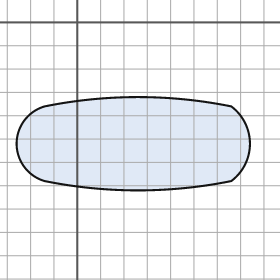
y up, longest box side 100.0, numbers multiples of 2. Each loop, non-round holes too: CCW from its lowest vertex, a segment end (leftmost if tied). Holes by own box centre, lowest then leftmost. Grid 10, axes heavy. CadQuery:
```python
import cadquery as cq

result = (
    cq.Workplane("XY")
    .moveTo(-14.0, -68.0)
    .threePointArc((26.0, -72.0), (66.0, -68.0))
    .threePointArc((74.0, -52.0), (66.0, -36.0))
    .threePointArc((26.0, -32.0), (-14.0, -36.0))
    .threePointArc((-26.0, -52.0), (-14.0, -68.0))
    .close()
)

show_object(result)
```